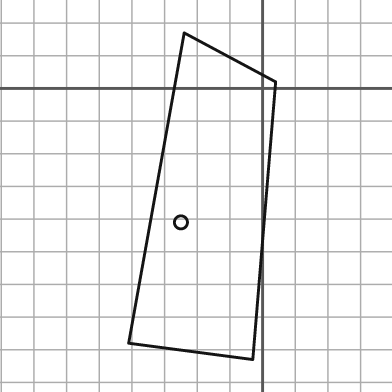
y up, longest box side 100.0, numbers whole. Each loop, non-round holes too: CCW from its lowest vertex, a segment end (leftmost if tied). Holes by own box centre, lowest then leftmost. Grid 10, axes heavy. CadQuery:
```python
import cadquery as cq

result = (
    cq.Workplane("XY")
    .moveTo(-3.0, -83.0)
    .lineTo(4.0, 2.0)
    .lineTo(-24.0, 17.0)
    .lineTo(-41.0, -78.0)
    .close()
    .moveTo(-25.0, -41.0)
    .circle(2.0)
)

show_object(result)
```